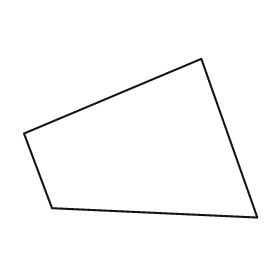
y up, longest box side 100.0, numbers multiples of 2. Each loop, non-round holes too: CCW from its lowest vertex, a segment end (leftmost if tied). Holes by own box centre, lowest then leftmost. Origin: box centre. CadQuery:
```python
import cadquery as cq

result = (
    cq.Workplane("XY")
    .moveTo(50.0, -34.0)
    .lineTo(26.0, 34.0)
    .lineTo(-50.0, 2.0)
    .lineTo(-38.0, -30.0)
    .close()
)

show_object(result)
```